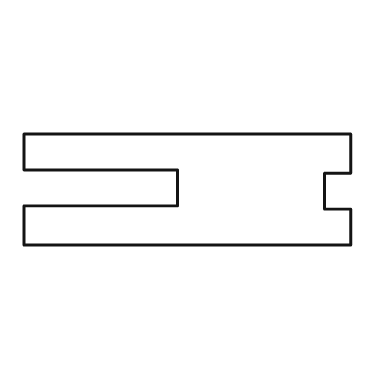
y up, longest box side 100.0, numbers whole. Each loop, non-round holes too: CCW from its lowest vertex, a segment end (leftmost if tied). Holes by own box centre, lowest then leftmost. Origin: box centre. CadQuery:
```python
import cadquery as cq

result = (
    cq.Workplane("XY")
    .moveTo(-50.0, -17.0)
    .lineTo(50.0, -17.0)
    .lineTo(50.0, -6.0)
    .lineTo(42.0, -6.0)
    .lineTo(42.0, 5.0)
    .lineTo(50.0, 5.0)
    .lineTo(50.0, 17.0)
    .lineTo(-50.0, 17.0)
    .lineTo(-50.0, 6.0)
    .lineTo(-3.0, 6.0)
    .lineTo(-3.0, -5.0)
    .lineTo(-50.0, -5.0)
    .close()
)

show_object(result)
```